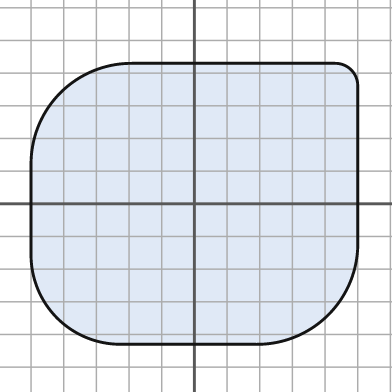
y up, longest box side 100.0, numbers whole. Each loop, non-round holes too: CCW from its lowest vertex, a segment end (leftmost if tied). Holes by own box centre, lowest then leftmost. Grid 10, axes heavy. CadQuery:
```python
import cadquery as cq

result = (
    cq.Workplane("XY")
    .moveTo(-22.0, -43.0)
    .lineTo(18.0, -43.0)
    .threePointArc((41.0, -34.0), (50.0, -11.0))
    .lineTo(50.0, 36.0)
    .threePointArc((48.0, 41.0), (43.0, 43.0))
    .lineTo(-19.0, 43.0)
    .threePointArc((-41.0, 34.0), (-50.0, 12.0))
    .lineTo(-50.0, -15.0)
    .threePointArc((-42.0, -35.0), (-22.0, -43.0))
    .close()
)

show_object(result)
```